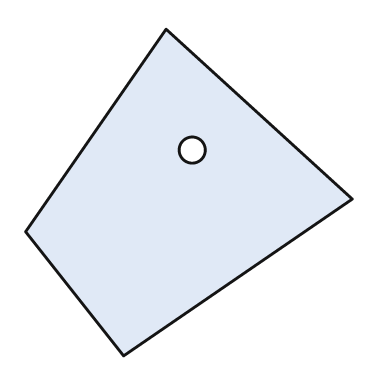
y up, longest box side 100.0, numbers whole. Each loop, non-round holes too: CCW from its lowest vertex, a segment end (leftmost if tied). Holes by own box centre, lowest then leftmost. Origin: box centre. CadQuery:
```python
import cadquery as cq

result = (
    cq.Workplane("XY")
    .moveTo(-20.0, -50.0)
    .lineTo(50.0, -2.0)
    .lineTo(-7.0, 50.0)
    .lineTo(-50.0, -12.0)
    .close()
    .moveTo(1.0, 13.0)
    .circle(4.0)
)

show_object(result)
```